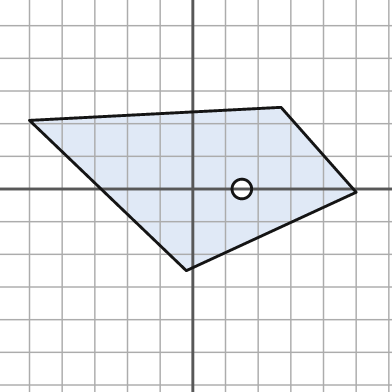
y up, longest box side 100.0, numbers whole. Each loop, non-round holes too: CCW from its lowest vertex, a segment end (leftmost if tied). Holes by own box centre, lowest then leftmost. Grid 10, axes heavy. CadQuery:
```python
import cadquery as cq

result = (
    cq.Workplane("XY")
    .moveTo(-2.0, -25.0)
    .lineTo(50.0, -1.0)
    .lineTo(27.0, 25.0)
    .lineTo(-50.0, 21.0)
    .close()
    .moveTo(15.0, 0.0)
    .circle(3.0)
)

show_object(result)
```